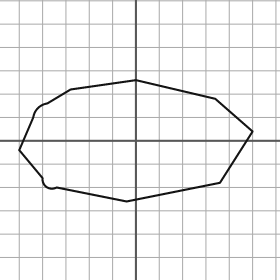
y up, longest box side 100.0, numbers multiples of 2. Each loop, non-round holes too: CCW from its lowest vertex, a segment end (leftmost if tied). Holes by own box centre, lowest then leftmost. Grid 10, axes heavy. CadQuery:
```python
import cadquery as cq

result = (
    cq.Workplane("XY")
    .moveTo(-4.0, -26.0)
    .lineTo(36.0, -18.0)
    .lineTo(50.0, 4.0)
    .lineTo(34.0, 18.0)
    .lineTo(0.0, 26.0)
    .lineTo(-28.0, 22.0)
    .lineTo(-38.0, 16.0)
    .threePointArc((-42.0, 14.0), (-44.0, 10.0))
    .lineTo(-50.0, -4.0)
    .lineTo(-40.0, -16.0)
    .threePointArc((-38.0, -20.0), (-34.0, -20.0))
    .close()
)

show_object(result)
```